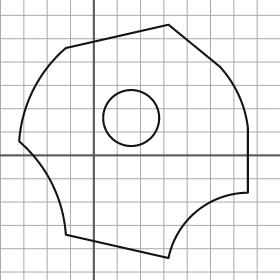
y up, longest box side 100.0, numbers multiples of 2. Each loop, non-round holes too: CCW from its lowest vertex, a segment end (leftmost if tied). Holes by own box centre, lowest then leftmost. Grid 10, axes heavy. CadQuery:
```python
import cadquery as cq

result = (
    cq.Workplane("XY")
    .moveTo(32.0, -44.0)
    .threePointArc((44.0, -24.0), (66.0, -16.0))
    .lineTo(66.0, 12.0)
    .threePointArc((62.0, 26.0), (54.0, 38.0))
    .lineTo(32.0, 56.0)
    .lineTo(-12.0, 46.0)
    .threePointArc((-26.0, 28.0), (-32.0, 6.0))
    .threePointArc((-18.0, -12.0), (-12.0, -34.0))
    .close()
    .moveTo(16.0, 16.0)
    .circle(12.0)
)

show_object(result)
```